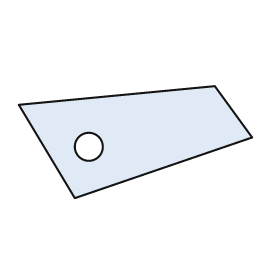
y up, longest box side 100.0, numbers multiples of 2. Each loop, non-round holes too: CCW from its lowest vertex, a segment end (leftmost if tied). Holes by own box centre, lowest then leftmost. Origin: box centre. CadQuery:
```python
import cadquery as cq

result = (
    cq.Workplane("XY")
    .moveTo(-26.0, -24.0)
    .lineTo(50.0, 2.0)
    .lineTo(34.0, 24.0)
    .lineTo(-50.0, 16.0)
    .close()
    .moveTo(-20.0, -2.0)
    .circle(6.0)
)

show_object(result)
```